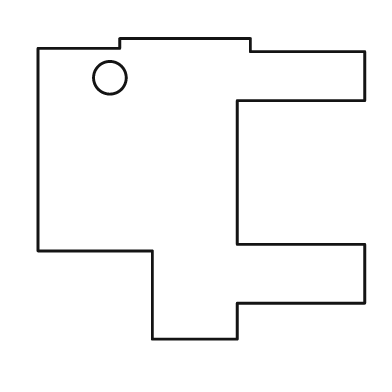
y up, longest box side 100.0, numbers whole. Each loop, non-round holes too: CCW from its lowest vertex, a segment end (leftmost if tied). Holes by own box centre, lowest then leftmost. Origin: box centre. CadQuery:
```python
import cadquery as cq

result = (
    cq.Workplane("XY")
    .moveTo(-15.0, -46.0)
    .lineTo(11.0, -46.0)
    .lineTo(11.0, -35.0)
    .lineTo(50.0, -35.0)
    .lineTo(50.0, -17.0)
    .lineTo(11.0, -17.0)
    .lineTo(11.0, 27.0)
    .lineTo(50.0, 27.0)
    .lineTo(50.0, 42.0)
    .lineTo(15.0, 42.0)
    .lineTo(15.0, 46.0)
    .lineTo(-25.0, 46.0)
    .lineTo(-25.0, 43.0)
    .lineTo(-50.0, 43.0)
    .lineTo(-50.0, -19.0)
    .lineTo(-15.0, -19.0)
    .close()
    .moveTo(-28.0, 34.0)
    .circle(5.0)
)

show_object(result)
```